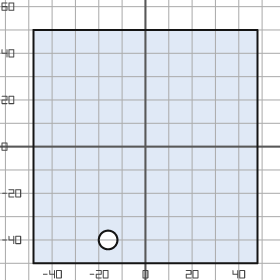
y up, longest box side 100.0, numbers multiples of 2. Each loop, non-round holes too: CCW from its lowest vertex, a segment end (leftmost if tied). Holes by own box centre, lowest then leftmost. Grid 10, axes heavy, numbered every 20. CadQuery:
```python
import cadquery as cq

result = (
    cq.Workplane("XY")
    .moveTo(-48.0, -50.0)
    .lineTo(48.0, -50.0)
    .lineTo(48.0, 50.0)
    .lineTo(-48.0, 50.0)
    .close()
    .moveTo(-16.0, -40.0)
    .circle(4.0)
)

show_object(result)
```